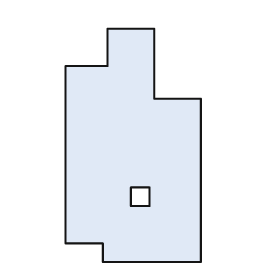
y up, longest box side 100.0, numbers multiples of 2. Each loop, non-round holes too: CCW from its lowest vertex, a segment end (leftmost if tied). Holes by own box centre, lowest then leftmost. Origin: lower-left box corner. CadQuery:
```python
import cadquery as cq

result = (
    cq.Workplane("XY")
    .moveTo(16.0, 0.0)
    .lineTo(58.0, 0.0)
    .lineTo(58.0, 70.0)
    .lineTo(38.0, 70.0)
    .lineTo(38.0, 100.0)
    .lineTo(18.0, 100.0)
    .lineTo(18.0, 84.0)
    .lineTo(0.0, 84.0)
    .lineTo(0.0, 8.0)
    .lineTo(16.0, 8.0)
    .close()
    .moveTo(28.0, 24.0)
    .lineTo(36.0, 24.0)
    .lineTo(36.0, 32.0)
    .lineTo(28.0, 32.0)
    .close()
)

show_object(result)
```